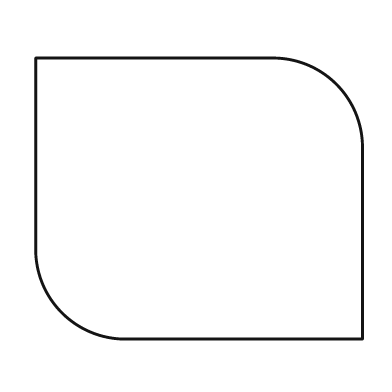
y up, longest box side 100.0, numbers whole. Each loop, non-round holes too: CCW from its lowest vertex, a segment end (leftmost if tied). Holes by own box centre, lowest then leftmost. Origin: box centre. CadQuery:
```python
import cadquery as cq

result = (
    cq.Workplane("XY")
    .moveTo(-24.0, -43.0)
    .lineTo(50.0, -43.0)
    .lineTo(50.0, 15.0)
    .threePointArc((42.0, 35.0), (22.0, 43.0))
    .lineTo(-50.0, 43.0)
    .lineTo(-50.0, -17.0)
    .threePointArc((-42.0, -35.0), (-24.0, -43.0))
    .close()
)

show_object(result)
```